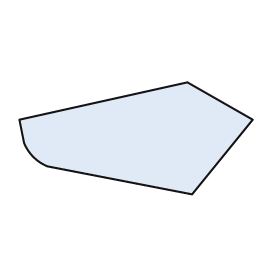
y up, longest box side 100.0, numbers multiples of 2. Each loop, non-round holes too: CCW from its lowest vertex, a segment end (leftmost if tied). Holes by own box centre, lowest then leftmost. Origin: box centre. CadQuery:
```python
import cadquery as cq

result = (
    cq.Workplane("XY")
    .moveTo(24.0, -24.0)
    .lineTo(50.0, 8.0)
    .lineTo(22.0, 24.0)
    .lineTo(-50.0, 8.0)
    .lineTo(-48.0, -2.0)
    .threePointArc((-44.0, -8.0), (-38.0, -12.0))
    .close()
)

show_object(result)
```